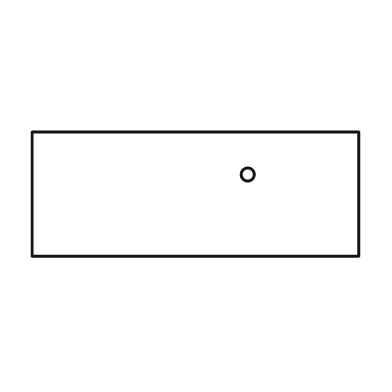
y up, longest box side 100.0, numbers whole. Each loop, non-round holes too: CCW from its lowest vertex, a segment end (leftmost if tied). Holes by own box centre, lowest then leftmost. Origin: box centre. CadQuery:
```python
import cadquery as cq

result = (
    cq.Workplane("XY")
    .moveTo(-50.0, -19.0)
    .lineTo(50.0, -19.0)
    .lineTo(50.0, 19.0)
    .lineTo(-50.0, 19.0)
    .close()
    .moveTo(16.0, 6.0)
    .circle(2.0)
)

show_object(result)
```